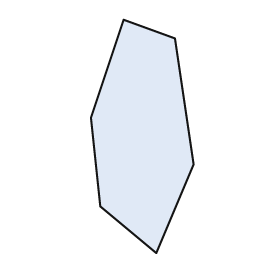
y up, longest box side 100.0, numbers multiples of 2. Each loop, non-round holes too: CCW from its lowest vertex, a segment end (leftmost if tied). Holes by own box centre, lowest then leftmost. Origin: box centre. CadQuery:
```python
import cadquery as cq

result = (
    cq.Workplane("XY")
    .moveTo(6.0, -50.0)
    .lineTo(22.0, -12.0)
    .lineTo(14.0, 42.0)
    .lineTo(-8.0, 50.0)
    .lineTo(-22.0, 8.0)
    .lineTo(-18.0, -30.0)
    .close()
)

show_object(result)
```